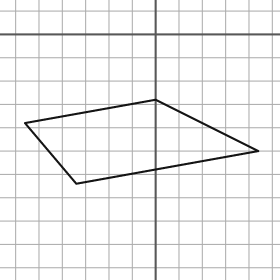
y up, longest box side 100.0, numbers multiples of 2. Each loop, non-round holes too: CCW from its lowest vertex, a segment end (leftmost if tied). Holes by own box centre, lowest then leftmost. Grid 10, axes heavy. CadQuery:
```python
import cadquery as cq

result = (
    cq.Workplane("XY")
    .moveTo(-34.0, -64.0)
    .lineTo(44.0, -50.0)
    .lineTo(0.0, -28.0)
    .lineTo(-56.0, -38.0)
    .close()
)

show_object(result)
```